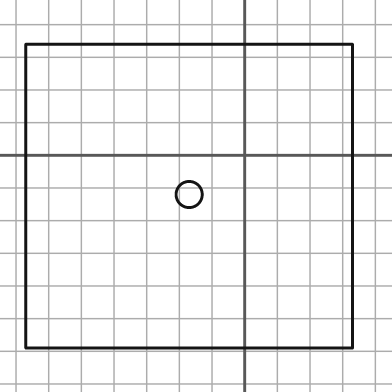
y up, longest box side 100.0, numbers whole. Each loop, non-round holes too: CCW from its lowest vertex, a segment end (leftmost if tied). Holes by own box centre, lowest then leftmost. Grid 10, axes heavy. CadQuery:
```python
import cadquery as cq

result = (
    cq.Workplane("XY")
    .moveTo(-67.0, -59.0)
    .lineTo(33.0, -59.0)
    .lineTo(33.0, 34.0)
    .lineTo(-67.0, 34.0)
    .close()
    .moveTo(-17.0, -12.0)
    .circle(4.0)
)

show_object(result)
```